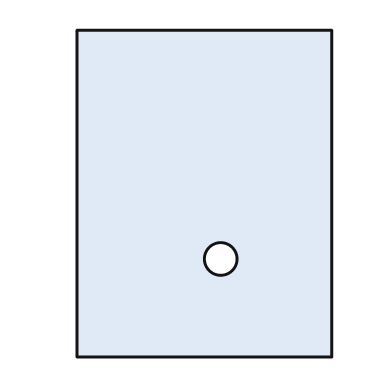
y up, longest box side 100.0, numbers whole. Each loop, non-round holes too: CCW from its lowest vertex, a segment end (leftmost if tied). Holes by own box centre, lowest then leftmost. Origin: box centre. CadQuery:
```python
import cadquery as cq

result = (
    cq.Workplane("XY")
    .moveTo(-39.0, -50.0)
    .lineTo(39.0, -50.0)
    .lineTo(39.0, 50.0)
    .lineTo(-39.0, 50.0)
    .close()
    .moveTo(5.0, -20.0)
    .circle(5.0)
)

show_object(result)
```